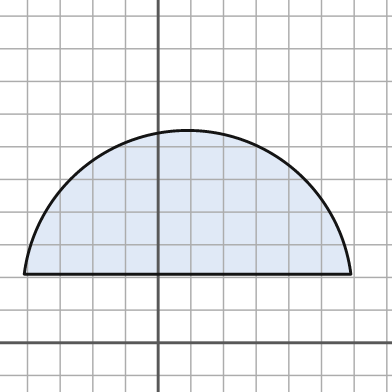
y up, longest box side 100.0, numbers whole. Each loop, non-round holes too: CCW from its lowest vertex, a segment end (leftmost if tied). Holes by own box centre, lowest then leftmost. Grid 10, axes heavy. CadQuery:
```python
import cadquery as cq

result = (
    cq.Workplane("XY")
    .moveTo(-41.0, 21.0)
    .lineTo(59.0, 21.0)
    .threePointArc((9.0, 65.0), (-41.0, 21.0))
    .close()
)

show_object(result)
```